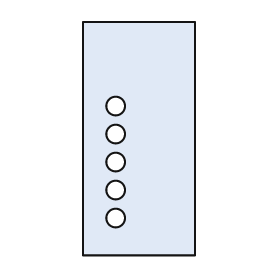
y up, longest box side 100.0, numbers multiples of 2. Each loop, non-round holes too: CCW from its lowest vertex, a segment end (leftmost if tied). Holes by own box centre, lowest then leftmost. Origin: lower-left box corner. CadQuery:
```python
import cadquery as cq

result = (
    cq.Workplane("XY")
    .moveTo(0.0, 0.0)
    .lineTo(48.0, 0.0)
    .lineTo(48.0, 100.0)
    .lineTo(0.0, 100.0)
    .close()
    .moveTo(14.0, 16.0)
    .circle(4.0)
    .moveTo(14.0, 28.0)
    .circle(4.0)
    .moveTo(14.0, 40.0)
    .circle(4.0)
    .moveTo(14.0, 52.0)
    .circle(4.0)
    .moveTo(14.0, 64.0)
    .circle(4.0)
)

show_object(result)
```